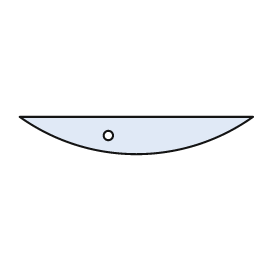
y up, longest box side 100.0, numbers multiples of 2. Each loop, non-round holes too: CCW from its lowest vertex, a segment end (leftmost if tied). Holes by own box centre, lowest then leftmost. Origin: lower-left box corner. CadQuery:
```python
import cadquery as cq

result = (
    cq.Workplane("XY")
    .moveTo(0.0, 16.0)
    .threePointArc((50.0, 0.0), (100.0, 16.0))
    .close()
    .moveTo(38.0, 8.0)
    .circle(2.0)
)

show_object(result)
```